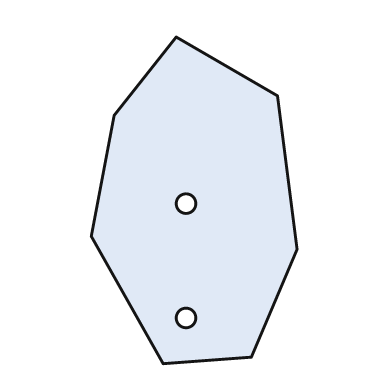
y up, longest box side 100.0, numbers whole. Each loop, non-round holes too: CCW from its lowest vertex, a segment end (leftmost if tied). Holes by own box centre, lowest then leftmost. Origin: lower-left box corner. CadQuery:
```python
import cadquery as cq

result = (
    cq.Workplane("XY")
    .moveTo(22.0, 0.0)
    .lineTo(49.0, 2.0)
    .lineTo(63.0, 35.0)
    .lineTo(57.0, 82.0)
    .lineTo(26.0, 100.0)
    .lineTo(7.0, 76.0)
    .lineTo(0.0, 39.0)
    .close()
    .moveTo(29.0, 14.0)
    .circle(3.0)
    .moveTo(29.0, 49.0)
    .circle(3.0)
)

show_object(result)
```